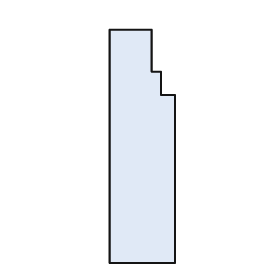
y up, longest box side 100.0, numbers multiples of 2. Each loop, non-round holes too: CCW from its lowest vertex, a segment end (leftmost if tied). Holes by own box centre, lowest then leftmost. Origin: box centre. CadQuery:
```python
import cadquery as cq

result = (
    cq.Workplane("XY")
    .moveTo(-14.0, -50.0)
    .lineTo(14.0, -50.0)
    .lineTo(14.0, 22.0)
    .lineTo(8.0, 22.0)
    .lineTo(8.0, 32.0)
    .lineTo(4.0, 32.0)
    .lineTo(4.0, 50.0)
    .lineTo(-14.0, 50.0)
    .close()
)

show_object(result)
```